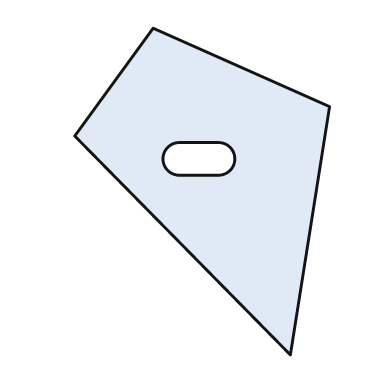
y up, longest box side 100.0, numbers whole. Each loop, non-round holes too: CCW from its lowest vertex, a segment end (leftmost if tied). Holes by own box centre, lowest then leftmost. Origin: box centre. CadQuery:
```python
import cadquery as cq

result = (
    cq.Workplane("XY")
    .moveTo(27.0, -50.0)
    .lineTo(39.0, 26.0)
    .lineTo(-15.0, 50.0)
    .lineTo(-39.0, 17.0)
    .close()
    .moveTo(-7.0, 5.0)
    .lineTo(5.0, 5.0)
    .threePointArc((10.0, 10.0), (5.0, 15.0))
    .lineTo(-7.0, 15.0)
    .threePointArc((-12.0, 10.0), (-7.0, 5.0))
    .close()
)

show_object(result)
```